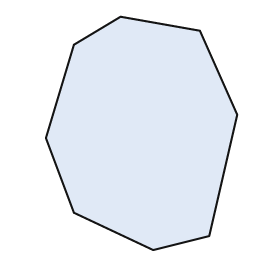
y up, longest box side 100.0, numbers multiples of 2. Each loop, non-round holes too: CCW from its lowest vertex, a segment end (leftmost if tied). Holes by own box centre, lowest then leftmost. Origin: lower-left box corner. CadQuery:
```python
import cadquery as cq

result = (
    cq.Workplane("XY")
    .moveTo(46.0, 0.0)
    .lineTo(70.0, 6.0)
    .lineTo(82.0, 58.0)
    .lineTo(66.0, 94.0)
    .lineTo(32.0, 100.0)
    .lineTo(12.0, 88.0)
    .lineTo(0.0, 48.0)
    .lineTo(12.0, 16.0)
    .close()
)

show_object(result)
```